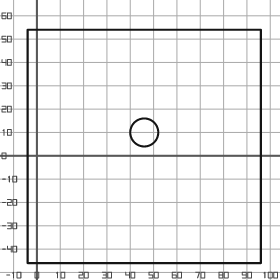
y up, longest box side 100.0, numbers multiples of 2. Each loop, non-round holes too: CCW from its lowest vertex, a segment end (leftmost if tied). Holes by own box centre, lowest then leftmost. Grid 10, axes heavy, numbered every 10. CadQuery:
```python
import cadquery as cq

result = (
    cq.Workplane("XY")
    .moveTo(-4.0, -46.0)
    .lineTo(96.0, -46.0)
    .lineTo(96.0, 54.0)
    .lineTo(-4.0, 54.0)
    .close()
    .moveTo(46.0, 10.0)
    .circle(6.0)
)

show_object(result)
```